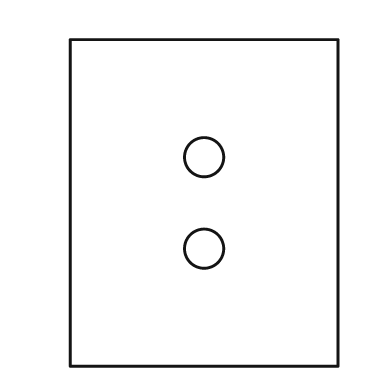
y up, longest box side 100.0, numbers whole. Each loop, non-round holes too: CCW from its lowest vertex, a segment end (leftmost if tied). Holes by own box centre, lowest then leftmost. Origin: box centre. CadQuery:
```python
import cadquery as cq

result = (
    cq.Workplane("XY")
    .moveTo(-41.0, -50.0)
    .lineTo(41.0, -50.0)
    .lineTo(41.0, 50.0)
    .lineTo(-41.0, 50.0)
    .close()
    .moveTo(0.0, -14.0)
    .circle(6.0)
    .moveTo(0.0, 14.0)
    .circle(6.0)
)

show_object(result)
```